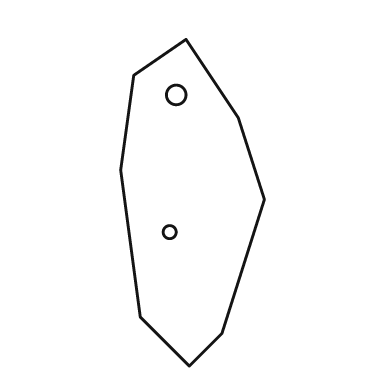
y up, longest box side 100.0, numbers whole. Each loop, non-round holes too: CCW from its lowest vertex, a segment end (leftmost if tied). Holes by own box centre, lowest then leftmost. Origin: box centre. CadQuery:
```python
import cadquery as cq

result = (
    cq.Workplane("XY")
    .moveTo(-1.0, -50.0)
    .lineTo(9.0, -40.0)
    .lineTo(22.0, 1.0)
    .lineTo(14.0, 26.0)
    .lineTo(-2.0, 50.0)
    .lineTo(-18.0, 39.0)
    .lineTo(-22.0, 10.0)
    .lineTo(-16.0, -35.0)
    .close()
    .moveTo(-7.0, -9.0)
    .circle(2.0)
    .moveTo(-5.0, 33.0)
    .circle(3.0)
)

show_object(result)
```